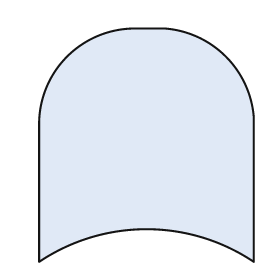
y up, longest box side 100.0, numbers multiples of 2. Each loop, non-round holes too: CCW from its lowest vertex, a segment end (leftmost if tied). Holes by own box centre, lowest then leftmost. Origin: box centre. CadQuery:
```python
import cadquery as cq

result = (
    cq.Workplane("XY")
    .moveTo(-46.0, -50.0)
    .threePointArc((0.0, -36.0), (46.0, -50.0))
    .lineTo(46.0, 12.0)
    .threePointArc((34.0, 38.0), (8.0, 50.0))
    .lineTo(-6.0, 50.0)
    .threePointArc((-34.0, 38.0), (-46.0, 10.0))
    .close()
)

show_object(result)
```